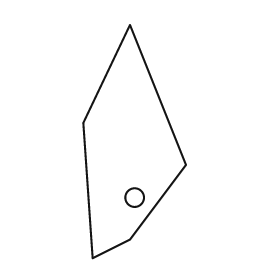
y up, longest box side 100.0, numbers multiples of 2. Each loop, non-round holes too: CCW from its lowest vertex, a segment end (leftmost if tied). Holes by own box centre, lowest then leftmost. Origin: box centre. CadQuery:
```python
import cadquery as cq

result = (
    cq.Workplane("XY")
    .moveTo(-18.0, -50.0)
    .lineTo(-2.0, -42.0)
    .lineTo(22.0, -10.0)
    .lineTo(-2.0, 50.0)
    .lineTo(-22.0, 8.0)
    .close()
    .moveTo(0.0, -24.0)
    .circle(4.0)
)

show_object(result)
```